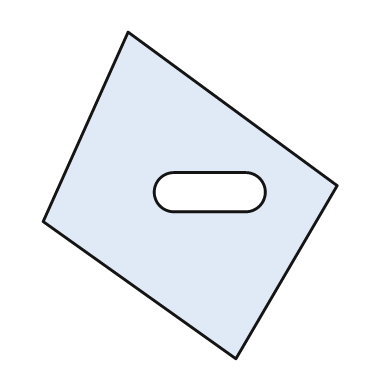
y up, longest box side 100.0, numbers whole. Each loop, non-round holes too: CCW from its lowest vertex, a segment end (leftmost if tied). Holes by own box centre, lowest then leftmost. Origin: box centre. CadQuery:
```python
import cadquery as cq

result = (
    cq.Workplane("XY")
    .moveTo(14.0, -50.0)
    .lineTo(45.0, 3.0)
    .lineTo(-19.0, 50.0)
    .lineTo(-45.0, -8.0)
    .close()
    .moveTo(-5.0, -5.0)
    .lineTo(17.0, -5.0)
    .threePointArc((23.0, 1.0), (17.0, 7.0))
    .lineTo(-5.0, 7.0)
    .threePointArc((-11.0, 1.0), (-5.0, -5.0))
    .close()
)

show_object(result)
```